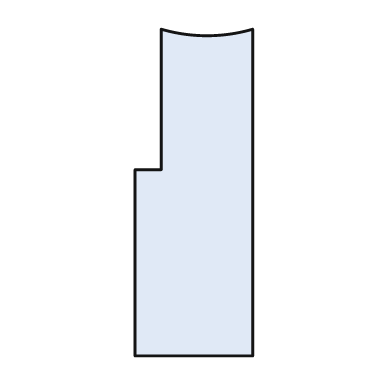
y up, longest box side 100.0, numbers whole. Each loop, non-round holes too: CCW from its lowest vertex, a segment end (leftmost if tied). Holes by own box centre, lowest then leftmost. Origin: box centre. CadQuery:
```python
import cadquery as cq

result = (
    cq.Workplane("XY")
    .moveTo(-18.0, -50.0)
    .lineTo(18.0, -50.0)
    .lineTo(18.0, 50.0)
    .threePointArc((4.0, 48.0), (-10.0, 50.0))
    .lineTo(-10.0, 7.0)
    .lineTo(-18.0, 7.0)
    .close()
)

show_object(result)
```